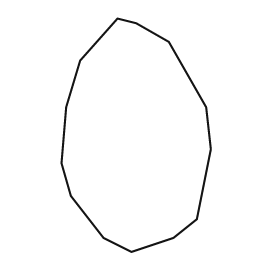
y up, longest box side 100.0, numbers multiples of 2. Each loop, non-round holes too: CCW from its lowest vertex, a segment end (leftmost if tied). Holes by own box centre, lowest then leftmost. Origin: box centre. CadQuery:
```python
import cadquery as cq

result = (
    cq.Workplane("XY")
    .moveTo(-2.0, -50.0)
    .lineTo(16.0, -44.0)
    .lineTo(26.0, -36.0)
    .lineTo(32.0, -6.0)
    .lineTo(30.0, 12.0)
    .lineTo(14.0, 40.0)
    .lineTo(0.0, 48.0)
    .lineTo(-8.0, 50.0)
    .lineTo(-24.0, 32.0)
    .lineTo(-30.0, 12.0)
    .lineTo(-32.0, -12.0)
    .lineTo(-28.0, -26.0)
    .lineTo(-14.0, -44.0)
    .close()
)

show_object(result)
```